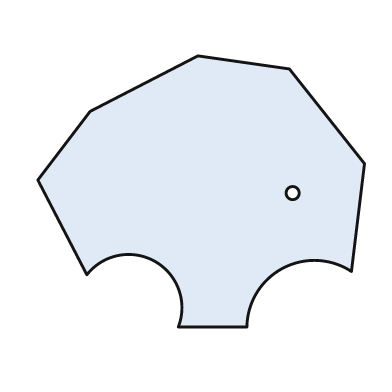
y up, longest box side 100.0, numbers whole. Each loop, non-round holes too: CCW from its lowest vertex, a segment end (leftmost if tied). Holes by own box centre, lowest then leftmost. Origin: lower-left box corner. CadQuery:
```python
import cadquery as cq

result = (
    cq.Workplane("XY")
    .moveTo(43.0, 0.0)
    .lineTo(64.0, 0.0)
    .threePointArc((75.0, 18.0), (96.0, 17.0))
    .lineTo(100.0, 50.0)
    .lineTo(77.0, 79.0)
    .lineTo(49.0, 83.0)
    .lineTo(16.0, 66.0)
    .lineTo(0.0, 45.0)
    .lineTo(15.0, 16.0)
    .threePointArc((36.0, 20.0), (43.0, 0.0))
    .close()
    .moveTo(78.0, 41.0)
    .circle(2.0)
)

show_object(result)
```